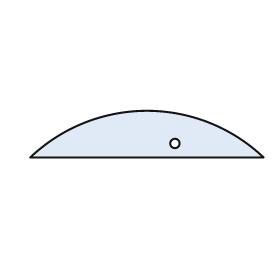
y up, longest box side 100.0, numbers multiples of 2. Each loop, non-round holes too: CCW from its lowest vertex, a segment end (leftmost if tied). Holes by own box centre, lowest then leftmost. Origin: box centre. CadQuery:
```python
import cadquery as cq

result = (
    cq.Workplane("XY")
    .moveTo(-50.0, -10.0)
    .lineTo(50.0, -10.0)
    .threePointArc((0.0, 10.0), (-50.0, -10.0))
    .close()
    .moveTo(12.0, -4.0)
    .circle(2.0)
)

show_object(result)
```